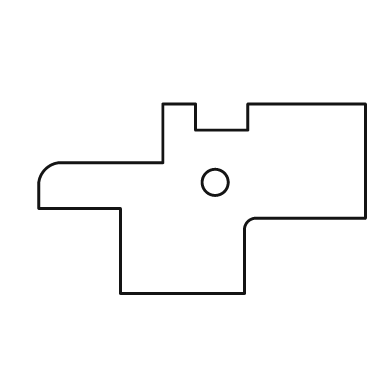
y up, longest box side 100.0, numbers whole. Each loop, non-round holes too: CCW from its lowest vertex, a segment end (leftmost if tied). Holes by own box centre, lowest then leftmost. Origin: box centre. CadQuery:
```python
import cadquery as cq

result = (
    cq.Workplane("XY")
    .moveTo(-25.0, -29.0)
    .lineTo(13.0, -29.0)
    .lineTo(13.0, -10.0)
    .threePointArc((14.0, -7.0), (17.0, -6.0))
    .lineTo(50.0, -6.0)
    .lineTo(50.0, 29.0)
    .lineTo(14.0, 29.0)
    .lineTo(14.0, 21.0)
    .lineTo(-2.0, 21.0)
    .lineTo(-2.0, 29.0)
    .lineTo(-12.0, 29.0)
    .lineTo(-12.0, 11.0)
    .lineTo(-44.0, 11.0)
    .threePointArc((-48.0, 9.0), (-50.0, 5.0))
    .lineTo(-50.0, -3.0)
    .lineTo(-25.0, -3.0)
    .close()
    .moveTo(4.0, 5.0)
    .circle(4.0)
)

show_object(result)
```